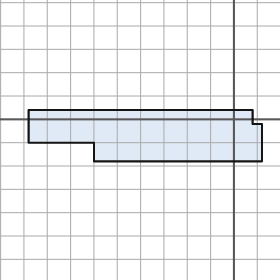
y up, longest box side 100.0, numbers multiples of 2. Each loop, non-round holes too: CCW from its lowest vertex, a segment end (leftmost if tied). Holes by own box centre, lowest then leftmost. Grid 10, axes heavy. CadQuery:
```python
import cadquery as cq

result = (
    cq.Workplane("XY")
    .moveTo(-60.0, -18.0)
    .lineTo(12.0, -18.0)
    .lineTo(12.0, -2.0)
    .lineTo(8.0, -2.0)
    .lineTo(8.0, 4.0)
    .lineTo(-88.0, 4.0)
    .lineTo(-88.0, -10.0)
    .lineTo(-60.0, -10.0)
    .close()
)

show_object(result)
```